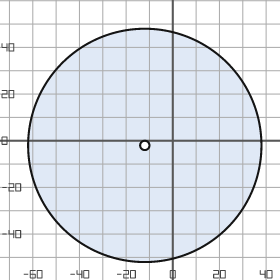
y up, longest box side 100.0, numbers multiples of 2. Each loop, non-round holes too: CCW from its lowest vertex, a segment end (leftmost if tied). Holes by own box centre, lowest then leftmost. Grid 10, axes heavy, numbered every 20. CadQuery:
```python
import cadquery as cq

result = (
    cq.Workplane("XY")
    .moveTo(-12.0, -2.0)
    .circle(50.0)
    .moveTo(-12.0, -2.0)
    .circle(2.0)
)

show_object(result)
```